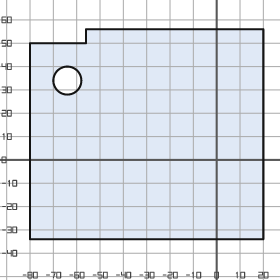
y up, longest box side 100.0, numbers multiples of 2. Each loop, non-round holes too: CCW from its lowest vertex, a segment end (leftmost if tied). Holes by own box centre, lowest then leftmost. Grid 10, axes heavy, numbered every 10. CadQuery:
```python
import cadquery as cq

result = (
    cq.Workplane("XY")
    .moveTo(-80.0, -34.0)
    .lineTo(20.0, -34.0)
    .lineTo(20.0, 56.0)
    .lineTo(-56.0, 56.0)
    .lineTo(-56.0, 50.0)
    .lineTo(-80.0, 50.0)
    .close()
    .moveTo(-64.0, 34.0)
    .circle(6.0)
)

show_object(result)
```